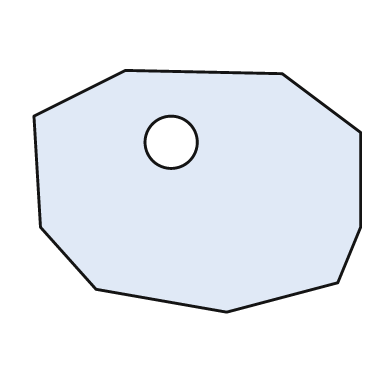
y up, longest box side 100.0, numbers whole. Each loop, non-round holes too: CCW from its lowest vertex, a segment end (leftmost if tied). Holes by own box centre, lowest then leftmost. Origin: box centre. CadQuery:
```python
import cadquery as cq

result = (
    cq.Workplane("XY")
    .moveTo(9.0, -37.0)
    .lineTo(43.0, -28.0)
    .lineTo(50.0, -11.0)
    .lineTo(50.0, 18.0)
    .lineTo(26.0, 36.0)
    .lineTo(-22.0, 37.0)
    .lineTo(-50.0, 23.0)
    .lineTo(-48.0, -11.0)
    .lineTo(-31.0, -30.0)
    .close()
    .moveTo(-8.0, 15.0)
    .circle(8.0)
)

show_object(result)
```